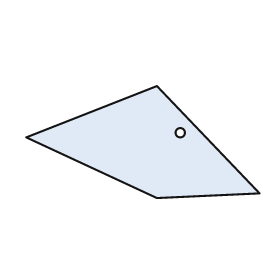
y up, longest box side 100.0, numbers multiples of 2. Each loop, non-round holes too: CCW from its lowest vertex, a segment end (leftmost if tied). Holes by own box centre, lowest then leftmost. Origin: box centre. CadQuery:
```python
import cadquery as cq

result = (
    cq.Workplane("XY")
    .moveTo(6.0, -24.0)
    .lineTo(50.0, -22.0)
    .lineTo(6.0, 24.0)
    .lineTo(-50.0, 2.0)
    .close()
    .moveTo(16.0, 4.0)
    .circle(2.0)
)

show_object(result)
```